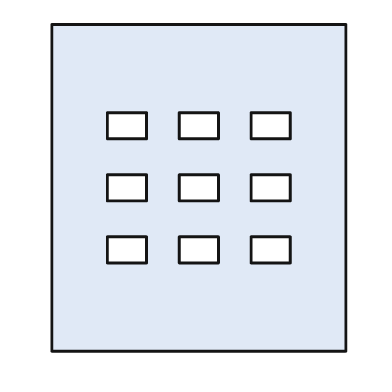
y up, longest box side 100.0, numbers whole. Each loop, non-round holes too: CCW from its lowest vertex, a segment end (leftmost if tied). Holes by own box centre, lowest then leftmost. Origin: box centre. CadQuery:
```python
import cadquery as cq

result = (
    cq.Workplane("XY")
    .moveTo(-45.0, -50.0)
    .lineTo(45.0, -50.0)
    .lineTo(45.0, 50.0)
    .lineTo(-45.0, 50.0)
    .close()
    .moveTo(-28.0, -23.0)
    .lineTo(-16.0, -23.0)
    .lineTo(-16.0, -15.0)
    .lineTo(-28.0, -15.0)
    .close()
    .moveTo(-6.0, -23.0)
    .lineTo(6.0, -23.0)
    .lineTo(6.0, -15.0)
    .lineTo(-6.0, -15.0)
    .close()
    .moveTo(16.0, -23.0)
    .lineTo(28.0, -23.0)
    .lineTo(28.0, -15.0)
    .lineTo(16.0, -15.0)
    .close()
    .moveTo(-28.0, -4.0)
    .lineTo(-16.0, -4.0)
    .lineTo(-16.0, 4.0)
    .lineTo(-28.0, 4.0)
    .close()
    .moveTo(-6.0, -4.0)
    .lineTo(6.0, -4.0)
    .lineTo(6.0, 4.0)
    .lineTo(-6.0, 4.0)
    .close()
    .moveTo(16.0, -4.0)
    .lineTo(28.0, -4.0)
    .lineTo(28.0, 4.0)
    .lineTo(16.0, 4.0)
    .close()
    .moveTo(-28.0, 15.0)
    .lineTo(-16.0, 15.0)
    .lineTo(-16.0, 23.0)
    .lineTo(-28.0, 23.0)
    .close()
    .moveTo(-6.0, 15.0)
    .lineTo(6.0, 15.0)
    .lineTo(6.0, 23.0)
    .lineTo(-6.0, 23.0)
    .close()
    .moveTo(16.0, 15.0)
    .lineTo(28.0, 15.0)
    .lineTo(28.0, 23.0)
    .lineTo(16.0, 23.0)
    .close()
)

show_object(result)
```